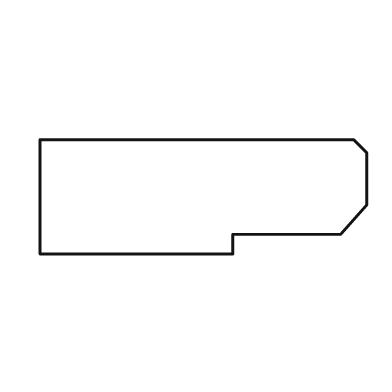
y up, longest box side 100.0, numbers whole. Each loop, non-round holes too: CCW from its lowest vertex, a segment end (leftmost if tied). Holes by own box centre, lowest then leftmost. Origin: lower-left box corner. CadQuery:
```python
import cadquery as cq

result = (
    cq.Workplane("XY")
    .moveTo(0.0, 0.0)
    .lineTo(59.0, 0.0)
    .lineTo(59.0, 6.0)
    .lineTo(92.0, 6.0)
    .lineTo(100.0, 15.0)
    .lineTo(100.0, 31.0)
    .lineTo(96.0, 35.0)
    .lineTo(0.0, 35.0)
    .close()
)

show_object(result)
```